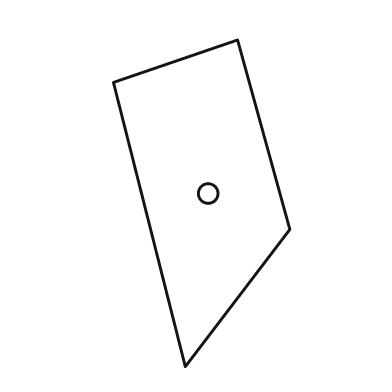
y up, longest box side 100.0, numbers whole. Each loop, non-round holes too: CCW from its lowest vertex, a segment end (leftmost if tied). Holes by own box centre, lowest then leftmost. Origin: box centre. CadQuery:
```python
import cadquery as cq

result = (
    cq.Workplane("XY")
    .moveTo(-5.0, -50.0)
    .lineTo(27.0, -8.0)
    .lineTo(11.0, 50.0)
    .lineTo(-27.0, 37.0)
    .close()
    .moveTo(2.0, 3.0)
    .circle(3.0)
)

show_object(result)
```